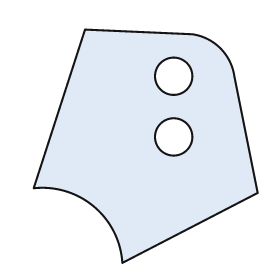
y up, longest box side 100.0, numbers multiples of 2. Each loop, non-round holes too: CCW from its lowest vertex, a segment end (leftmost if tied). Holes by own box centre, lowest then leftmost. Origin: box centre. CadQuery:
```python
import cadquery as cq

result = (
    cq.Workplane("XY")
    .moveTo(-10.0, -50.0)
    .lineTo(48.0, -20.0)
    .lineTo(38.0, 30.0)
    .threePointArc((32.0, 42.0), (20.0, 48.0))
    .lineTo(-26.0, 50.0)
    .lineTo(-48.0, -18.0)
    .threePointArc((-22.0, -26.0), (-10.0, -50.0))
    .close()
    .moveTo(12.0, 4.0)
    .circle(8.0)
    .moveTo(12.0, 30.0)
    .circle(8.0)
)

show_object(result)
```